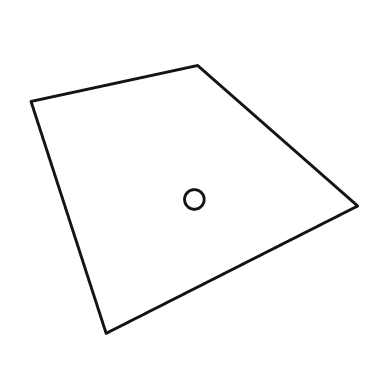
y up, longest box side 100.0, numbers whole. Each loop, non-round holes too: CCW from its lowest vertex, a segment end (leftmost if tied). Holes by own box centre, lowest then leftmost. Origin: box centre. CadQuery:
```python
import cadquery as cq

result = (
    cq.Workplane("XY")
    .moveTo(-27.0, -41.0)
    .lineTo(50.0, -2.0)
    .lineTo(1.0, 41.0)
    .lineTo(-50.0, 30.0)
    .close()
    .moveTo(0.0, 0.0)
    .circle(3.0)
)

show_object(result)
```